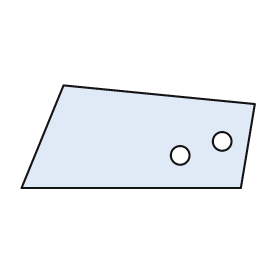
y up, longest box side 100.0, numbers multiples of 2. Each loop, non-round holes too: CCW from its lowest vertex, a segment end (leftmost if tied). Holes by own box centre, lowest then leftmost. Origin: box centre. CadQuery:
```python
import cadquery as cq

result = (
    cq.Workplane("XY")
    .moveTo(-50.0, -22.0)
    .lineTo(44.0, -22.0)
    .lineTo(50.0, 14.0)
    .lineTo(-32.0, 22.0)
    .close()
    .moveTo(18.0, -8.0)
    .circle(4.0)
    .moveTo(36.0, -2.0)
    .circle(4.0)
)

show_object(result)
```